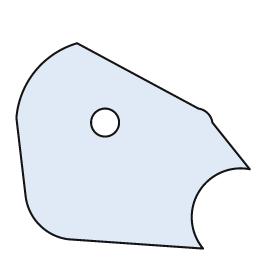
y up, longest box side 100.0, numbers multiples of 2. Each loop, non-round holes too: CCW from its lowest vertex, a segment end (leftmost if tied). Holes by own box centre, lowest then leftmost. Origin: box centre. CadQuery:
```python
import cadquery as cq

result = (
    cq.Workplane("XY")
    .moveTo(30.0, -44.0)
    .threePointArc((28.0, -20.0), (50.0, -10.0))
    .lineTo(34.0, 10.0)
    .threePointArc((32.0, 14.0), (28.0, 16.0))
    .lineTo(-24.0, 44.0)
    .threePointArc((-42.0, 32.0), (-50.0, 12.0))
    .lineTo(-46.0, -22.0)
    .threePointArc((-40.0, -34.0), (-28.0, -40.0))
    .close()
    .moveTo(-12.0, 10.0)
    .circle(6.0)
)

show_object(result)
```